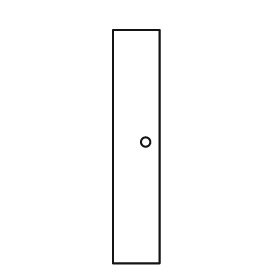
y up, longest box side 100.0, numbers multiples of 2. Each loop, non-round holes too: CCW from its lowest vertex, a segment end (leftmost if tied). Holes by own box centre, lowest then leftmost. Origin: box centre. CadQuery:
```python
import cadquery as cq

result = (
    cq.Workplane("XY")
    .moveTo(-10.0, -50.0)
    .lineTo(10.0, -50.0)
    .lineTo(10.0, 50.0)
    .lineTo(-10.0, 50.0)
    .close()
    .moveTo(4.0, 2.0)
    .circle(2.0)
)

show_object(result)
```